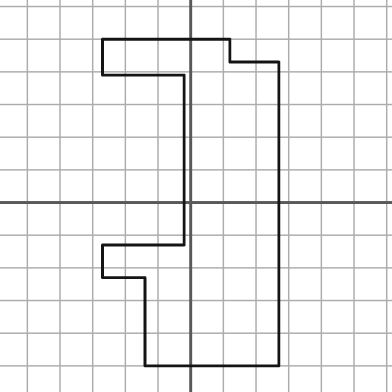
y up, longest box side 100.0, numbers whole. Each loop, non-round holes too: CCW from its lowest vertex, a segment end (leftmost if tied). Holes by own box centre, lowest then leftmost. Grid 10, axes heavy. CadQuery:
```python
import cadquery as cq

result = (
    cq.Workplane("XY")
    .moveTo(-14.0, -50.0)
    .lineTo(27.0, -50.0)
    .lineTo(27.0, 43.0)
    .lineTo(12.0, 43.0)
    .lineTo(12.0, 50.0)
    .lineTo(-27.0, 50.0)
    .lineTo(-27.0, 39.0)
    .lineTo(-2.0, 39.0)
    .lineTo(-2.0, -13.0)
    .lineTo(-27.0, -13.0)
    .lineTo(-27.0, -23.0)
    .lineTo(-14.0, -23.0)
    .close()
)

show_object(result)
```